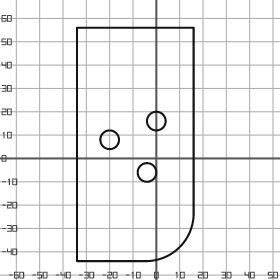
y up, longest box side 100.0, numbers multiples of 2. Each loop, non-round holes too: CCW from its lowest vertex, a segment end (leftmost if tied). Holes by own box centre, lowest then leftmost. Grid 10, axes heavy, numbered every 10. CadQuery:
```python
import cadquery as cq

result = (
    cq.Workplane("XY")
    .moveTo(-34.0, -44.0)
    .lineTo(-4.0, -44.0)
    .threePointArc((10.0, -38.0), (16.0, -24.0))
    .lineTo(16.0, 56.0)
    .lineTo(-34.0, 56.0)
    .close()
    .moveTo(-4.0, -6.0)
    .circle(4.0)
    .moveTo(-20.0, 8.0)
    .circle(4.0)
    .moveTo(0.0, 16.0)
    .circle(4.0)
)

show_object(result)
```